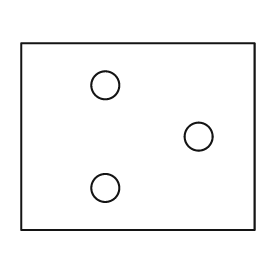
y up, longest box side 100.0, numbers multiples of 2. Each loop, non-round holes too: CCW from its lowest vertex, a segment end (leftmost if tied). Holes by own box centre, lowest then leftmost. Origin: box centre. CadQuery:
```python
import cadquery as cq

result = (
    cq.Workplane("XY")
    .moveTo(-50.0, -40.0)
    .lineTo(50.0, -40.0)
    .lineTo(50.0, 40.0)
    .lineTo(-50.0, 40.0)
    .close()
    .moveTo(-14.0, -22.0)
    .circle(6.0)
    .moveTo(26.0, 0.0)
    .circle(6.0)
    .moveTo(-14.0, 22.0)
    .circle(6.0)
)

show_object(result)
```